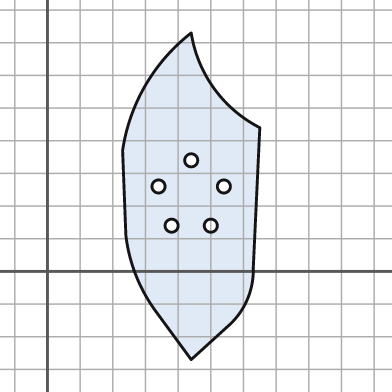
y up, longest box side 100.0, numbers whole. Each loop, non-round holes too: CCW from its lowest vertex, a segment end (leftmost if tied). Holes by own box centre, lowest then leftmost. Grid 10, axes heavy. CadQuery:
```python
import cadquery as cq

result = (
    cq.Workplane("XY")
    .moveTo(44.0, -27.0)
    .lineTo(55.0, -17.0)
    .threePointArc((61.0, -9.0), (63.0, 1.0))
    .lineTo(65.0, 44.0)
    .threePointArc((51.0, 56.0), (44.0, 73.0))
    .threePointArc((30.0, 57.0), (23.0, 37.0))
    .lineTo(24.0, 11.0)
    .threePointArc((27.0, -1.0), (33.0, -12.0))
    .close()
    .moveTo(38.0, 14.0)
    .circle(2.0)
    .moveTo(50.0, 14.0)
    .circle(2.0)
    .moveTo(34.0, 26.0)
    .circle(2.0)
    .moveTo(54.0, 26.0)
    .circle(2.0)
    .moveTo(44.0, 34.0)
    .circle(2.0)
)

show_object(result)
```